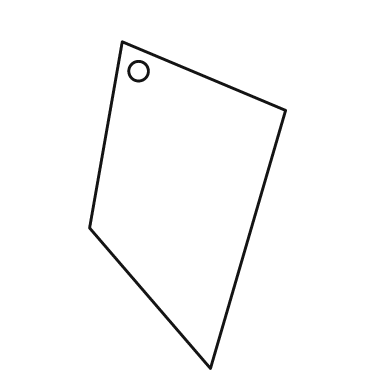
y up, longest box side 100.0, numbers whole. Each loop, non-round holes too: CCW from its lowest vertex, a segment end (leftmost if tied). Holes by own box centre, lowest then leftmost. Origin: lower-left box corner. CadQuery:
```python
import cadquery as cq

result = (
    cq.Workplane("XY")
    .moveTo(37.0, 0.0)
    .lineTo(60.0, 79.0)
    .lineTo(10.0, 100.0)
    .lineTo(0.0, 43.0)
    .close()
    .moveTo(15.0, 91.0)
    .circle(3.0)
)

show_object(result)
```